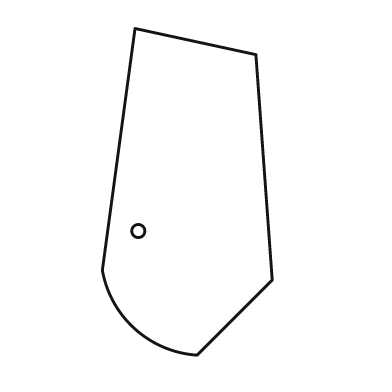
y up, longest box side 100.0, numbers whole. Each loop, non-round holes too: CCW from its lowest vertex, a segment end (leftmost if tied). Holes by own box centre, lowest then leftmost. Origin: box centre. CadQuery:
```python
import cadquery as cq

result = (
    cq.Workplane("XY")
    .moveTo(3.0, -50.0)
    .lineTo(26.0, -27.0)
    .lineTo(21.0, 42.0)
    .lineTo(-16.0, 50.0)
    .lineTo(-26.0, -24.0)
    .threePointArc((-16.0, -42.0), (3.0, -50.0))
    .close()
    .moveTo(-15.0, -12.0)
    .circle(2.0)
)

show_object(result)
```